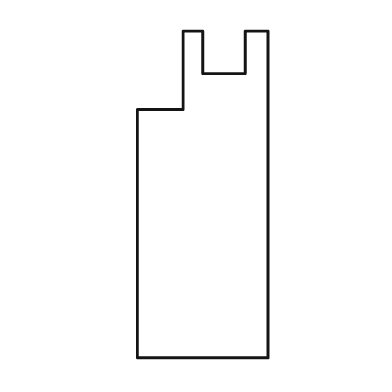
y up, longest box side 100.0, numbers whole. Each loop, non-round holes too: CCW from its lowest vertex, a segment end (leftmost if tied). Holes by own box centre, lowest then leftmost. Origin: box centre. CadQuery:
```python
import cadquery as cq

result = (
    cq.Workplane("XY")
    .moveTo(-20.0, -50.0)
    .lineTo(20.0, -50.0)
    .lineTo(20.0, 50.0)
    .lineTo(13.0, 50.0)
    .lineTo(13.0, 37.0)
    .lineTo(0.0, 37.0)
    .lineTo(0.0, 50.0)
    .lineTo(-6.0, 50.0)
    .lineTo(-6.0, 26.0)
    .lineTo(-20.0, 26.0)
    .close()
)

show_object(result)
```